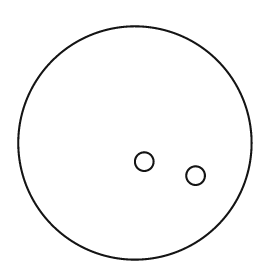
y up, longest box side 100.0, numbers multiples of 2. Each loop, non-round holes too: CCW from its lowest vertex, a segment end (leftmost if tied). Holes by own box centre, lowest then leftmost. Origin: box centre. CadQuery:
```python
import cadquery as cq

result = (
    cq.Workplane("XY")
    .moveTo(0.0, 0.0)
    .circle(50.0)
    .moveTo(26.0, -14.0)
    .circle(4.0)
    .moveTo(4.0, -8.0)
    .circle(4.0)
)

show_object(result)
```